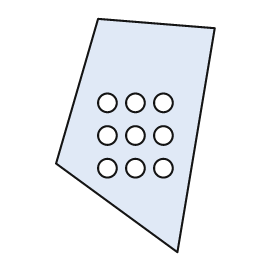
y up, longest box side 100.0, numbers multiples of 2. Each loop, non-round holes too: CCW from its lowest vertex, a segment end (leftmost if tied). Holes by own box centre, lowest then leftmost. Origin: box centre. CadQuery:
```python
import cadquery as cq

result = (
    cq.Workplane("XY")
    .moveTo(18.0, -50.0)
    .lineTo(34.0, 46.0)
    .lineTo(-16.0, 50.0)
    .lineTo(-34.0, -12.0)
    .close()
    .moveTo(-12.0, -14.0)
    .circle(4.0)
    .moveTo(0.0, -14.0)
    .circle(4.0)
    .moveTo(12.0, -14.0)
    .circle(4.0)
    .moveTo(-12.0, 0.0)
    .circle(4.0)
    .moveTo(0.0, 0.0)
    .circle(4.0)
    .moveTo(12.0, 0.0)
    .circle(4.0)
    .moveTo(-12.0, 14.0)
    .circle(4.0)
    .moveTo(0.0, 14.0)
    .circle(4.0)
    .moveTo(12.0, 14.0)
    .circle(4.0)
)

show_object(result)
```